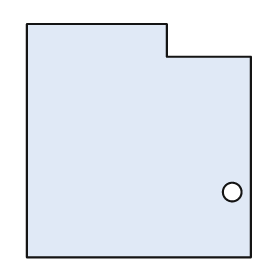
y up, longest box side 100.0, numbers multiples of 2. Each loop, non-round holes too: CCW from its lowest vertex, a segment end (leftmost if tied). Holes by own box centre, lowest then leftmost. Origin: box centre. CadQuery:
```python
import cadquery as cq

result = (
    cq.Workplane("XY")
    .moveTo(-48.0, -50.0)
    .lineTo(48.0, -50.0)
    .lineTo(48.0, 36.0)
    .lineTo(12.0, 36.0)
    .lineTo(12.0, 50.0)
    .lineTo(-48.0, 50.0)
    .close()
    .moveTo(40.0, -22.0)
    .circle(4.0)
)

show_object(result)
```